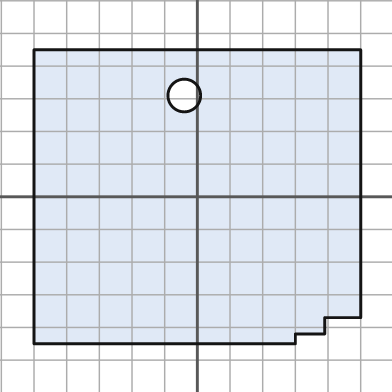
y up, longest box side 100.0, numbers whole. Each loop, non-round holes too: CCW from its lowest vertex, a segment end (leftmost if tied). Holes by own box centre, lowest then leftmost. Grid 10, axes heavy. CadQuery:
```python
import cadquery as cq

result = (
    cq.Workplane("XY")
    .moveTo(-50.0, -45.0)
    .lineTo(30.0, -45.0)
    .lineTo(30.0, -42.0)
    .lineTo(39.0, -42.0)
    .lineTo(39.0, -37.0)
    .lineTo(50.0, -37.0)
    .lineTo(50.0, 45.0)
    .lineTo(-50.0, 45.0)
    .close()
    .moveTo(-4.0, 31.0)
    .circle(5.0)
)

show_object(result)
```